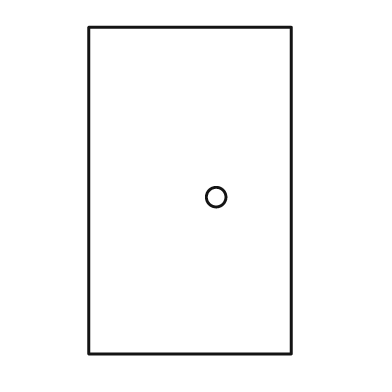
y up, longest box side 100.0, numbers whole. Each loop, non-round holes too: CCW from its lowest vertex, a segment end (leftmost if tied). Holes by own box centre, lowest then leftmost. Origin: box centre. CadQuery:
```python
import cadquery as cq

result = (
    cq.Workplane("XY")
    .moveTo(-31.0, -50.0)
    .lineTo(31.0, -50.0)
    .lineTo(31.0, 50.0)
    .lineTo(-31.0, 50.0)
    .close()
    .moveTo(8.0, -2.0)
    .circle(3.0)
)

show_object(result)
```